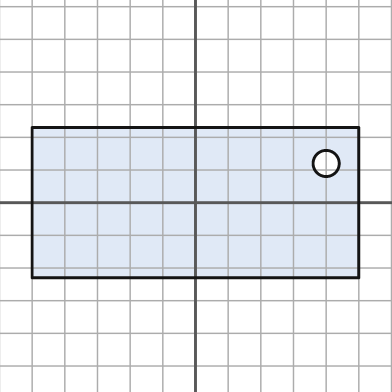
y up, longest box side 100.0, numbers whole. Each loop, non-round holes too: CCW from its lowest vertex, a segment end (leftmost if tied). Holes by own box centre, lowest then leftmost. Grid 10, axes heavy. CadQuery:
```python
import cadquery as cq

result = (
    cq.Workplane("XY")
    .moveTo(-50.0, -23.0)
    .lineTo(50.0, -23.0)
    .lineTo(50.0, 23.0)
    .lineTo(-50.0, 23.0)
    .close()
    .moveTo(40.0, 12.0)
    .circle(4.0)
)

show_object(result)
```